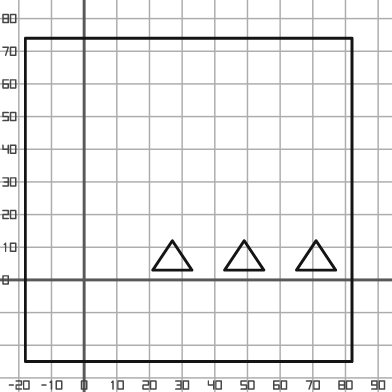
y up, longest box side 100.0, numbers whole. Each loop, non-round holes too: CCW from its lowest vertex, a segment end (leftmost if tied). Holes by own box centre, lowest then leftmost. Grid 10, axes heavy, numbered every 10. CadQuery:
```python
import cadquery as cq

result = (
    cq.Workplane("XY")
    .moveTo(-18.0, -25.0)
    .lineTo(82.0, -25.0)
    .lineTo(82.0, 74.0)
    .lineTo(-18.0, 74.0)
    .close()
    .moveTo(21.0, 3.0)
    .lineTo(33.0, 3.0)
    .lineTo(27.0, 12.0)
    .close()
    .moveTo(43.0, 3.0)
    .lineTo(55.0, 3.0)
    .lineTo(49.0, 12.0)
    .close()
    .moveTo(65.0, 3.0)
    .lineTo(77.0, 3.0)
    .lineTo(71.0, 12.0)
    .close()
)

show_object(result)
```